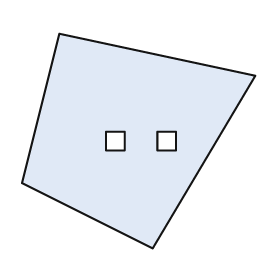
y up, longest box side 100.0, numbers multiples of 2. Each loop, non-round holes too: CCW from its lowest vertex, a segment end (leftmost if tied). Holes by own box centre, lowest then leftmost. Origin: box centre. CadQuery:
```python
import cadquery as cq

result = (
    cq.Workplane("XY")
    .moveTo(6.0, -46.0)
    .lineTo(50.0, 28.0)
    .lineTo(-34.0, 46.0)
    .lineTo(-50.0, -18.0)
    .close()
    .moveTo(-14.0, -4.0)
    .lineTo(-6.0, -4.0)
    .lineTo(-6.0, 4.0)
    .lineTo(-14.0, 4.0)
    .close()
    .moveTo(8.0, -4.0)
    .lineTo(16.0, -4.0)
    .lineTo(16.0, 4.0)
    .lineTo(8.0, 4.0)
    .close()
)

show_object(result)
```